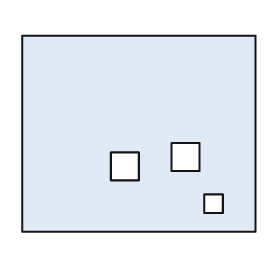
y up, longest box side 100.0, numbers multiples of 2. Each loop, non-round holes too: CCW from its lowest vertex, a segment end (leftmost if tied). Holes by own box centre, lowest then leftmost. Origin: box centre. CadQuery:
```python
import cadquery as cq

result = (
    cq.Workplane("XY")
    .moveTo(-50.0, -42.0)
    .lineTo(50.0, -42.0)
    .lineTo(50.0, 42.0)
    .lineTo(-50.0, 42.0)
    .close()
    .moveTo(28.0, -34.0)
    .lineTo(36.0, -34.0)
    .lineTo(36.0, -26.0)
    .lineTo(28.0, -26.0)
    .close()
    .moveTo(-12.0, -20.0)
    .lineTo(0.0, -20.0)
    .lineTo(0.0, -8.0)
    .lineTo(-12.0, -8.0)
    .close()
    .moveTo(14.0, -16.0)
    .lineTo(26.0, -16.0)
    .lineTo(26.0, -4.0)
    .lineTo(14.0, -4.0)
    .close()
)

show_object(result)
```